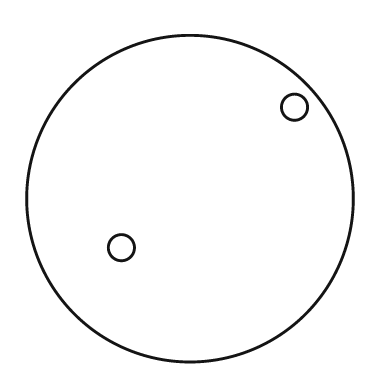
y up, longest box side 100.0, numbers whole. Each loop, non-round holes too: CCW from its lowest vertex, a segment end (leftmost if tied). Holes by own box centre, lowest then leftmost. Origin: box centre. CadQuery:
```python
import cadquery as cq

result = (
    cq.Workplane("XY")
    .moveTo(0.0, 0.0)
    .circle(50.0)
    .moveTo(-21.0, -15.0)
    .circle(4.0)
    .moveTo(32.0, 28.0)
    .circle(4.0)
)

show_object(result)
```